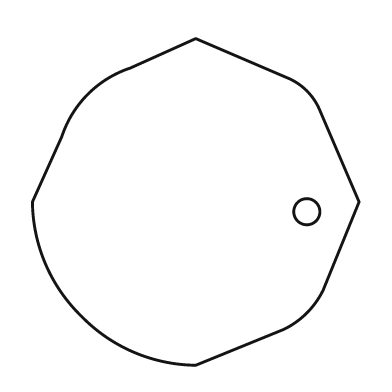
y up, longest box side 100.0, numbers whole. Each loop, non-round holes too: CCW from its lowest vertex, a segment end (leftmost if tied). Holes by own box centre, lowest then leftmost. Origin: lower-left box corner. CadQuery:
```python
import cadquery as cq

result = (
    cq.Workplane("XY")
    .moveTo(50.0, 0.0)
    .lineTo(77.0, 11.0)
    .threePointArc((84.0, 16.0), (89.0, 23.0))
    .lineTo(100.0, 50.0)
    .lineTo(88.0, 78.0)
    .threePointArc((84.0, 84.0), (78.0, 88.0))
    .lineTo(50.0, 100.0)
    .lineTo(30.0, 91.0)
    .threePointArc((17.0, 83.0), (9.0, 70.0))
    .lineTo(0.0, 50.0)
    .threePointArc((4.0, 31.0), (15.0, 15.0))
    .threePointArc((31.0, 4.0), (50.0, 0.0))
    .close()
    .moveTo(84.0, 47.0)
    .circle(4.0)
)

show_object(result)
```